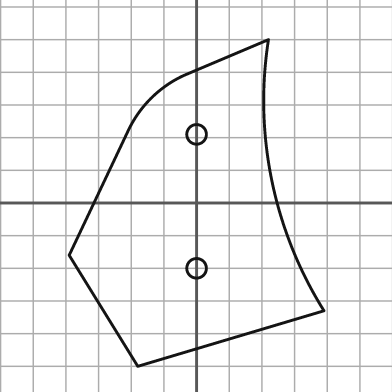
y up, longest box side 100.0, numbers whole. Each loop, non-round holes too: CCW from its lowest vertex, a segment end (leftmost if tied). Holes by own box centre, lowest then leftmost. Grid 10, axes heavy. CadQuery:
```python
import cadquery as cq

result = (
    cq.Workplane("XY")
    .moveTo(-18.0, -50.0)
    .lineTo(39.0, -33.0)
    .threePointArc((23.0, 7.0), (22.0, 50.0))
    .lineTo(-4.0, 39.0)
    .threePointArc((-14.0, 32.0), (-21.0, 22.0))
    .lineTo(-39.0, -16.0)
    .close()
    .moveTo(0.0, -20.0)
    .circle(3.0)
    .moveTo(0.0, 21.0)
    .circle(3.0)
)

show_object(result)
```